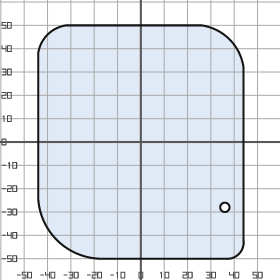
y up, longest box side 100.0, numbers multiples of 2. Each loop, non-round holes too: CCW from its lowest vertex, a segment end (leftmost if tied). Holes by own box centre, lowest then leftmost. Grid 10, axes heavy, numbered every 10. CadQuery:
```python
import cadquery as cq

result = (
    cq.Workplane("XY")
    .moveTo(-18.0, -50.0)
    .lineTo(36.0, -50.0)
    .threePointArc((42.0, -48.0), (44.0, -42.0))
    .lineTo(44.0, 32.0)
    .threePointArc((38.0, 44.0), (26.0, 50.0))
    .lineTo(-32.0, 50.0)
    .threePointArc((-40.0, 46.0), (-44.0, 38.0))
    .lineTo(-44.0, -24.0)
    .threePointArc((-36.0, -42.0), (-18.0, -50.0))
    .close()
    .moveTo(36.0, -28.0)
    .circle(2.0)
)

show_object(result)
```